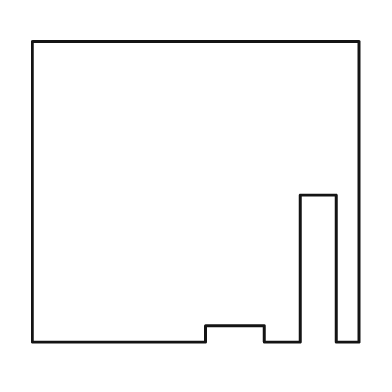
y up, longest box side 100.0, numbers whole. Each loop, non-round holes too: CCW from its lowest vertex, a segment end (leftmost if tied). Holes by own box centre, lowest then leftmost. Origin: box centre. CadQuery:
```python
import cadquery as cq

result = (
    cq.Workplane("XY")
    .moveTo(-50.0, -46.0)
    .lineTo(3.0, -46.0)
    .lineTo(3.0, -41.0)
    .lineTo(21.0, -41.0)
    .lineTo(21.0, -46.0)
    .lineTo(32.0, -46.0)
    .lineTo(32.0, -1.0)
    .lineTo(43.0, -1.0)
    .lineTo(43.0, -46.0)
    .lineTo(50.0, -46.0)
    .lineTo(50.0, 46.0)
    .lineTo(-50.0, 46.0)
    .close()
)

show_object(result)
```